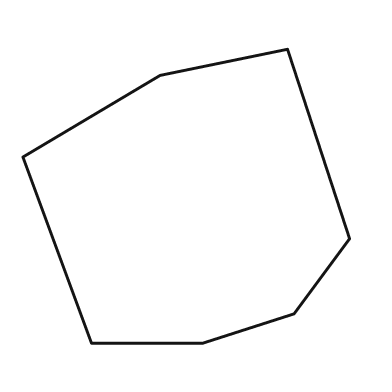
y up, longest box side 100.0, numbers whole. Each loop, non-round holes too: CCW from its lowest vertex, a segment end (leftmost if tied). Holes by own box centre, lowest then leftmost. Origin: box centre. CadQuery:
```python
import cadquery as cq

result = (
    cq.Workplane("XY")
    .moveTo(-29.0, -45.0)
    .lineTo(5.0, -45.0)
    .lineTo(33.0, -36.0)
    .lineTo(50.0, -13.0)
    .lineTo(31.0, 45.0)
    .lineTo(-8.0, 37.0)
    .lineTo(-50.0, 12.0)
    .close()
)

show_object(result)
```